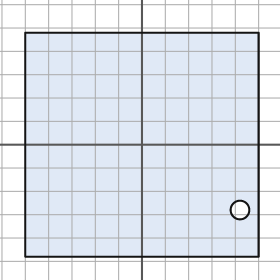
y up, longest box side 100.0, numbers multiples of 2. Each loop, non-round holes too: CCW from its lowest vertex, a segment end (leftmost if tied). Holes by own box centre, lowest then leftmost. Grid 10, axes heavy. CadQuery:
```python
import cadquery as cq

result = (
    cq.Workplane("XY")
    .moveTo(-50.0, -48.0)
    .lineTo(50.0, -48.0)
    .lineTo(50.0, 48.0)
    .lineTo(-50.0, 48.0)
    .close()
    .moveTo(42.0, -28.0)
    .circle(4.0)
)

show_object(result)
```